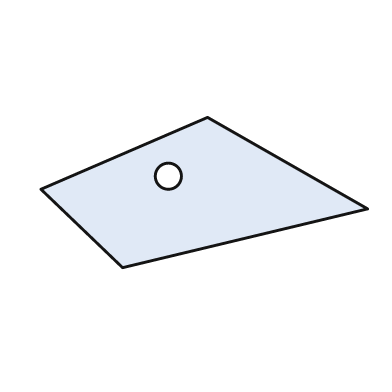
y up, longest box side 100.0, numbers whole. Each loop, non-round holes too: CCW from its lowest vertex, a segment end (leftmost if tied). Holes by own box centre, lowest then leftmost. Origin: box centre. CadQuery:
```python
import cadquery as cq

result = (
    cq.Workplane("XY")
    .moveTo(-25.0, -23.0)
    .lineTo(50.0, -5.0)
    .lineTo(1.0, 23.0)
    .lineTo(-50.0, 1.0)
    .close()
    .moveTo(-11.0, 5.0)
    .circle(4.0)
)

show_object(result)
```